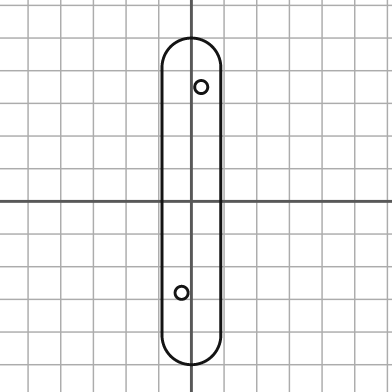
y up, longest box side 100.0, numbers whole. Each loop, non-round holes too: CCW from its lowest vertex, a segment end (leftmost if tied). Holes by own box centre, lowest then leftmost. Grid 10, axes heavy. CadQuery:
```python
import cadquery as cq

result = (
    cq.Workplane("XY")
    .moveTo(-9.0, -41.0)
    .threePointArc((0.0, -50.0), (9.0, -41.0))
    .lineTo(9.0, 41.0)
    .threePointArc((0.0, 50.0), (-9.0, 41.0))
    .close()
    .moveTo(-3.0, -28.0)
    .circle(2.0)
    .moveTo(3.0, 35.0)
    .circle(2.0)
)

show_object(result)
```